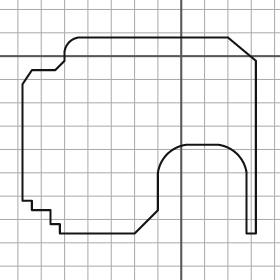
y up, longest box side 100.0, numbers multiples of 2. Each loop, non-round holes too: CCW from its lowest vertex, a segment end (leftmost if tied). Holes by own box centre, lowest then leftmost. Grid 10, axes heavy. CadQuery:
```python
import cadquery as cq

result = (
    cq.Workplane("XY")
    .moveTo(-52.0, -76.0)
    .lineTo(-20.0, -76.0)
    .lineTo(-10.0, -66.0)
    .lineTo(-10.0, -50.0)
    .threePointArc((-6.0, -42.0), (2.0, -38.0))
    .lineTo(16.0, -38.0)
    .threePointArc((24.0, -42.0), (28.0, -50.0))
    .lineTo(28.0, -76.0)
    .lineTo(32.0, -76.0)
    .lineTo(32.0, -2.0)
    .lineTo(20.0, 8.0)
    .lineTo(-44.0, 8.0)
    .threePointArc((-48.0, 6.0), (-50.0, 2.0))
    .lineTo(-50.0, -2.0)
    .lineTo(-54.0, -6.0)
    .lineTo(-64.0, -6.0)
    .lineTo(-68.0, -12.0)
    .lineTo(-68.0, -62.0)
    .lineTo(-64.0, -62.0)
    .lineTo(-64.0, -66.0)
    .lineTo(-56.0, -66.0)
    .lineTo(-56.0, -72.0)
    .lineTo(-52.0, -72.0)
    .close()
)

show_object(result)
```